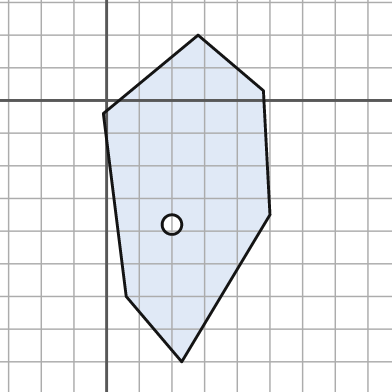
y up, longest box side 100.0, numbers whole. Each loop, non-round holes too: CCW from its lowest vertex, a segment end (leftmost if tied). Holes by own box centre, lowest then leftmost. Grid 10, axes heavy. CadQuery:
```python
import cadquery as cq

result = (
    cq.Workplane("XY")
    .moveTo(23.0, -80.0)
    .lineTo(50.0, -35.0)
    .lineTo(48.0, 3.0)
    .lineTo(28.0, 20.0)
    .lineTo(-1.0, -4.0)
    .lineTo(6.0, -60.0)
    .close()
    .moveTo(20.0, -38.0)
    .circle(3.0)
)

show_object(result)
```